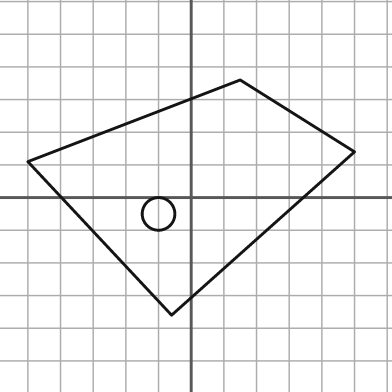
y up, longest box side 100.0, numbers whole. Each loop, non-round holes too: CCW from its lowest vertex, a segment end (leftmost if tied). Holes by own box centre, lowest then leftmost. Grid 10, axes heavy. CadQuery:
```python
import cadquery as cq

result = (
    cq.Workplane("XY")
    .moveTo(-6.0, -36.0)
    .lineTo(50.0, 14.0)
    .lineTo(15.0, 36.0)
    .lineTo(-50.0, 11.0)
    .close()
    .moveTo(-10.0, -5.0)
    .circle(5.0)
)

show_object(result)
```